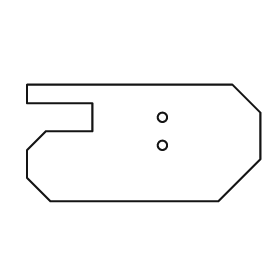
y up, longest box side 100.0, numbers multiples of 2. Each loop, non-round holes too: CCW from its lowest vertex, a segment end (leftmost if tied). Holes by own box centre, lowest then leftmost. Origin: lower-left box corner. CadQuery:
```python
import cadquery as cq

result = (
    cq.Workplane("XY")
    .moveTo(10.0, 0.0)
    .lineTo(82.0, 0.0)
    .lineTo(100.0, 18.0)
    .lineTo(100.0, 38.0)
    .lineTo(88.0, 50.0)
    .lineTo(0.0, 50.0)
    .lineTo(0.0, 42.0)
    .lineTo(28.0, 42.0)
    .lineTo(28.0, 30.0)
    .lineTo(8.0, 30.0)
    .lineTo(0.0, 22.0)
    .lineTo(0.0, 10.0)
    .close()
    .moveTo(58.0, 24.0)
    .circle(2.0)
    .moveTo(58.0, 36.0)
    .circle(2.0)
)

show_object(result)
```